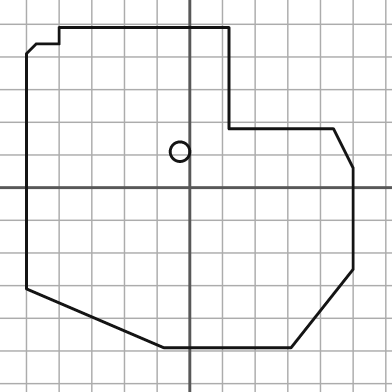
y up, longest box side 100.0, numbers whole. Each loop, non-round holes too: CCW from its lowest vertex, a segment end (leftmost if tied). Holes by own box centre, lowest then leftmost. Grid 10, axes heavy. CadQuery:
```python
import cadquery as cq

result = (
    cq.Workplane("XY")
    .moveTo(-8.0, -49.0)
    .lineTo(31.0, -49.0)
    .lineTo(50.0, -25.0)
    .lineTo(50.0, 6.0)
    .lineTo(44.0, 18.0)
    .lineTo(12.0, 18.0)
    .lineTo(12.0, 49.0)
    .lineTo(-40.0, 49.0)
    .lineTo(-40.0, 44.0)
    .lineTo(-47.0, 44.0)
    .lineTo(-50.0, 41.0)
    .lineTo(-50.0, -31.0)
    .close()
    .moveTo(-3.0, 11.0)
    .circle(3.0)
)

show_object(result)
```